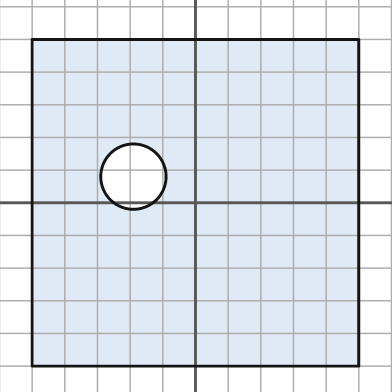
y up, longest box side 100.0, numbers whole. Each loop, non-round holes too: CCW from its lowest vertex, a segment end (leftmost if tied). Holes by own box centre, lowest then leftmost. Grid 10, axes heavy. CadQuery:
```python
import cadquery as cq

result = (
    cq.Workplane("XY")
    .moveTo(-50.0, -50.0)
    .lineTo(50.0, -50.0)
    .lineTo(50.0, 50.0)
    .lineTo(-50.0, 50.0)
    .close()
    .moveTo(-19.0, 8.0)
    .circle(10.0)
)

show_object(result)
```